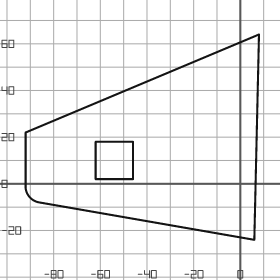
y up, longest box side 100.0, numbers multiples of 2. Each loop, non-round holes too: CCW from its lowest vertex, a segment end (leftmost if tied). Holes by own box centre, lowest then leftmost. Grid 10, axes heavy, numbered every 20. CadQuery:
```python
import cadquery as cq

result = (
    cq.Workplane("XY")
    .moveTo(6.0, -24.0)
    .lineTo(8.0, 64.0)
    .lineTo(-92.0, 22.0)
    .lineTo(-92.0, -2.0)
    .threePointArc((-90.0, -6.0), (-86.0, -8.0))
    .close()
    .moveTo(-62.0, 2.0)
    .lineTo(-46.0, 2.0)
    .lineTo(-46.0, 18.0)
    .lineTo(-62.0, 18.0)
    .close()
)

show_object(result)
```